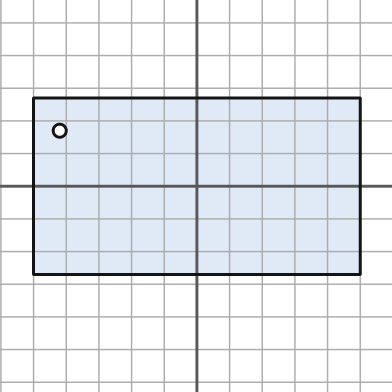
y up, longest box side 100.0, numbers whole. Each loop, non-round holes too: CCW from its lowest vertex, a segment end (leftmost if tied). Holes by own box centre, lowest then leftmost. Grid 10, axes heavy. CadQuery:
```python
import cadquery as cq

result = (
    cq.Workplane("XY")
    .moveTo(-50.0, -27.0)
    .lineTo(50.0, -27.0)
    .lineTo(50.0, 27.0)
    .lineTo(-50.0, 27.0)
    .close()
    .moveTo(-42.0, 17.0)
    .circle(2.0)
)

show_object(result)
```